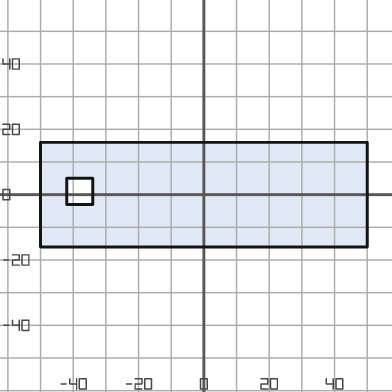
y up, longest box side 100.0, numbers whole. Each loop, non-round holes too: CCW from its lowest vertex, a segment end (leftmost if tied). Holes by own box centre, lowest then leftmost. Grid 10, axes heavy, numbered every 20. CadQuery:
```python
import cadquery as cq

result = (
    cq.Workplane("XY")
    .moveTo(-50.0, -16.0)
    .lineTo(50.0, -16.0)
    .lineTo(50.0, 16.0)
    .lineTo(-50.0, 16.0)
    .close()
    .moveTo(-42.0, -3.0)
    .lineTo(-34.0, -3.0)
    .lineTo(-34.0, 5.0)
    .lineTo(-42.0, 5.0)
    .close()
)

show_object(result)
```